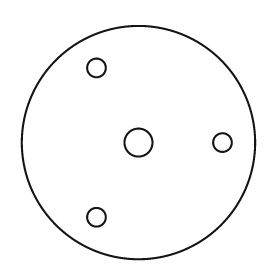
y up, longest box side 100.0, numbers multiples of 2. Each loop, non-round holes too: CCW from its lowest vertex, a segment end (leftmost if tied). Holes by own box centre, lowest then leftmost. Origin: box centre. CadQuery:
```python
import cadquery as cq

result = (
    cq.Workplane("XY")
    .moveTo(0.0, 0.0)
    .circle(50.0)
    .moveTo(-18.0, -32.0)
    .circle(4.0)
    .moveTo(0.0, 0.0)
    .circle(6.0)
    .moveTo(36.0, 0.0)
    .circle(4.0)
    .moveTo(-18.0, 32.0)
    .circle(4.0)
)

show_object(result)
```